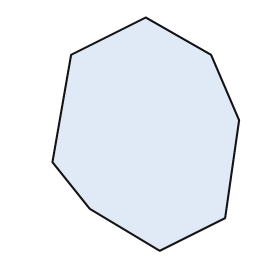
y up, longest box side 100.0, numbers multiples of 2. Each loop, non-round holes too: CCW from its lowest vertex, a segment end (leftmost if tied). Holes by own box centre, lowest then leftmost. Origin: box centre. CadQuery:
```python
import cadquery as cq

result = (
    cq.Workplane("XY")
    .moveTo(6.0, -50.0)
    .lineTo(34.0, -36.0)
    .lineTo(40.0, 6.0)
    .lineTo(28.0, 34.0)
    .lineTo(0.0, 50.0)
    .lineTo(-32.0, 34.0)
    .lineTo(-40.0, -12.0)
    .lineTo(-24.0, -32.0)
    .close()
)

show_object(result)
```